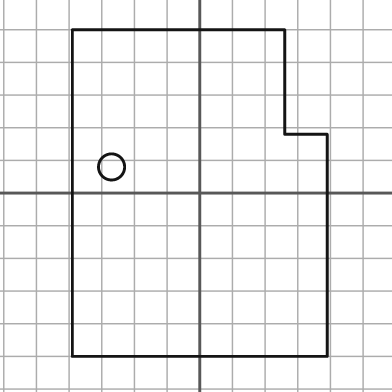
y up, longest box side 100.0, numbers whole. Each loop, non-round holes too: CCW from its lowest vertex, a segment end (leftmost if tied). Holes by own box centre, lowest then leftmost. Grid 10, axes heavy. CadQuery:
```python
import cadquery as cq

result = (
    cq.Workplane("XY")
    .moveTo(-39.0, -50.0)
    .lineTo(39.0, -50.0)
    .lineTo(39.0, 18.0)
    .lineTo(26.0, 18.0)
    .lineTo(26.0, 50.0)
    .lineTo(-39.0, 50.0)
    .close()
    .moveTo(-27.0, 8.0)
    .circle(4.0)
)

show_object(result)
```